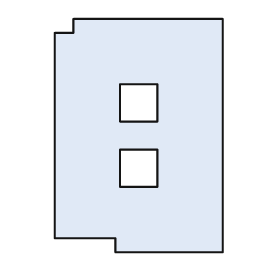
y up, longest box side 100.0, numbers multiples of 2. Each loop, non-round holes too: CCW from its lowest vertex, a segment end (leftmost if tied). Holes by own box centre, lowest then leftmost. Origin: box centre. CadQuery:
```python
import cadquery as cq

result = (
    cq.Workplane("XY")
    .moveTo(-10.0, -50.0)
    .lineTo(36.0, -50.0)
    .lineTo(36.0, 50.0)
    .lineTo(-28.0, 50.0)
    .lineTo(-28.0, 44.0)
    .lineTo(-36.0, 44.0)
    .lineTo(-36.0, -44.0)
    .lineTo(-10.0, -44.0)
    .close()
    .moveTo(-8.0, -22.0)
    .lineTo(8.0, -22.0)
    .lineTo(8.0, -6.0)
    .lineTo(-8.0, -6.0)
    .close()
    .moveTo(-8.0, 6.0)
    .lineTo(8.0, 6.0)
    .lineTo(8.0, 22.0)
    .lineTo(-8.0, 22.0)
    .close()
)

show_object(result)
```